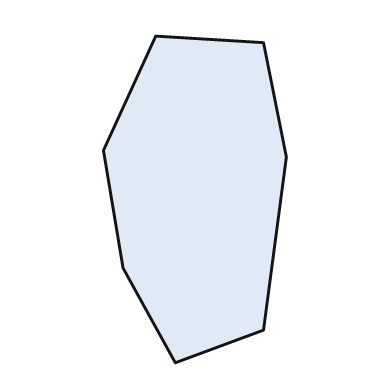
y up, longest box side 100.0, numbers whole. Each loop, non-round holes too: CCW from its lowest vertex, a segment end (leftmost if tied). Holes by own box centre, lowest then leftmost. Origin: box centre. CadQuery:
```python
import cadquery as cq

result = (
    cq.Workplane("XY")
    .moveTo(-6.0, -50.0)
    .lineTo(21.0, -40.0)
    .lineTo(28.0, 13.0)
    .lineTo(21.0, 48.0)
    .lineTo(-12.0, 50.0)
    .lineTo(-28.0, 15.0)
    .lineTo(-22.0, -21.0)
    .close()
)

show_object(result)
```